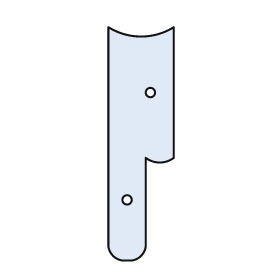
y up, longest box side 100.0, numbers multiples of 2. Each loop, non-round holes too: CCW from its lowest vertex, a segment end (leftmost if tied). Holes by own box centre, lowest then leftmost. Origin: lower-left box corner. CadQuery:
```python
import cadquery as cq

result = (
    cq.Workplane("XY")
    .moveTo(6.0, 0.0)
    .lineTo(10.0, 0.0)
    .threePointArc((14.0, 2.0), (16.0, 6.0))
    .lineTo(16.0, 44.0)
    .threePointArc((22.0, 42.0), (28.0, 44.0))
    .lineTo(28.0, 100.0)
    .threePointArc((14.0, 96.0), (0.0, 100.0))
    .lineTo(0.0, 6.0)
    .threePointArc((2.0, 2.0), (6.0, 0.0))
    .close()
    .moveTo(8.0, 26.0)
    .circle(2.0)
    .moveTo(18.0, 72.0)
    .circle(2.0)
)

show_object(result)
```